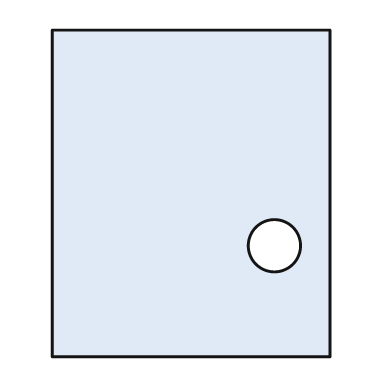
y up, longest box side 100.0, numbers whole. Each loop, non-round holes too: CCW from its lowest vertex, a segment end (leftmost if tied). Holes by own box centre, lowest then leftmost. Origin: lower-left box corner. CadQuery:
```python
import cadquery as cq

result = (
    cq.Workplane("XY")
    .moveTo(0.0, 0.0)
    .lineTo(85.0, 0.0)
    .lineTo(85.0, 100.0)
    .lineTo(0.0, 100.0)
    .close()
    .moveTo(68.0, 34.0)
    .circle(8.0)
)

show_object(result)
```